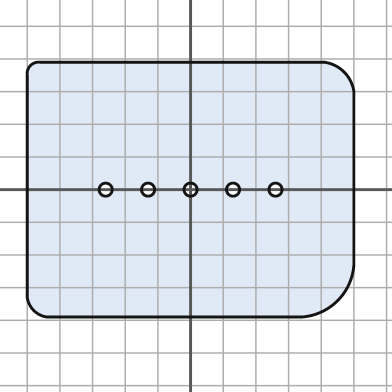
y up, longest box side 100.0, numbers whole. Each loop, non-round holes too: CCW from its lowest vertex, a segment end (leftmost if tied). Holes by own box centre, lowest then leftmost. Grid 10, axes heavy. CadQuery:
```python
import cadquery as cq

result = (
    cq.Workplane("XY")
    .moveTo(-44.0, -39.0)
    .lineTo(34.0, -39.0)
    .threePointArc((45.0, -34.0), (50.0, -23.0))
    .lineTo(50.0, 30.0)
    .threePointArc((47.0, 36.0), (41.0, 39.0))
    .lineTo(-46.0, 39.0)
    .threePointArc((-49.0, 38.0), (-50.0, 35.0))
    .lineTo(-50.0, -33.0)
    .threePointArc((-48.0, -37.0), (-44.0, -39.0))
    .close()
    .moveTo(-26.0, 0.0)
    .circle(2.0)
    .moveTo(-13.0, 0.0)
    .circle(2.0)
    .moveTo(0.0, 0.0)
    .circle(2.0)
    .moveTo(13.0, 0.0)
    .circle(2.0)
    .moveTo(26.0, 0.0)
    .circle(2.0)
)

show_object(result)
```